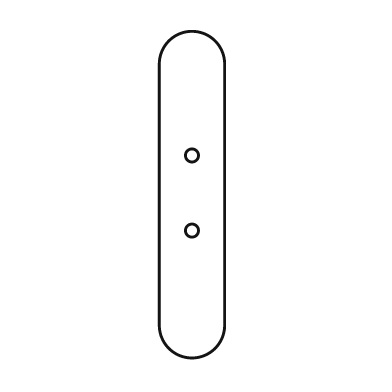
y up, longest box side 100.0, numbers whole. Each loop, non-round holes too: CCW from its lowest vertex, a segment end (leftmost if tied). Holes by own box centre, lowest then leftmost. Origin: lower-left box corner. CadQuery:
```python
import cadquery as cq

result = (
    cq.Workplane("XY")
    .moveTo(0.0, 10.0)
    .threePointArc((10.0, 0.0), (20.0, 10.0))
    .lineTo(20.0, 90.0)
    .threePointArc((10.0, 100.0), (0.0, 90.0))
    .close()
    .moveTo(10.0, 39.0)
    .circle(2.0)
    .moveTo(10.0, 62.0)
    .circle(2.0)
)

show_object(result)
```